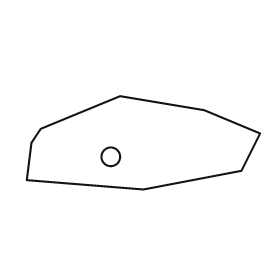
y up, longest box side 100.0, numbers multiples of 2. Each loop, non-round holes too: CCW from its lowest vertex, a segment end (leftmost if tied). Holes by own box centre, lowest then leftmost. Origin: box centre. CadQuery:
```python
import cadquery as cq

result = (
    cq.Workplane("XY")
    .moveTo(0.0, -20.0)
    .lineTo(42.0, -12.0)
    .lineTo(50.0, 4.0)
    .lineTo(26.0, 14.0)
    .lineTo(-10.0, 20.0)
    .lineTo(-44.0, 6.0)
    .lineTo(-48.0, 0.0)
    .lineTo(-50.0, -16.0)
    .close()
    .moveTo(-14.0, -6.0)
    .circle(4.0)
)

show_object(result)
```